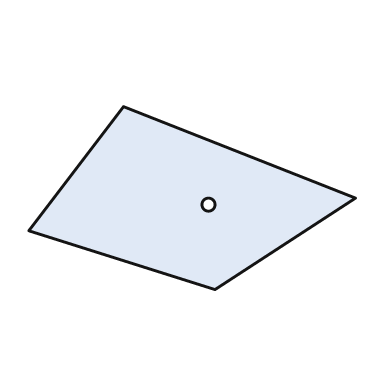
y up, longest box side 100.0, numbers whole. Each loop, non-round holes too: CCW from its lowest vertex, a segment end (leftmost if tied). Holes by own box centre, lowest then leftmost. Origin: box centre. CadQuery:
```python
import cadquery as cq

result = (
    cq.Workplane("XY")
    .moveTo(7.0, -28.0)
    .lineTo(50.0, 0.0)
    .lineTo(-21.0, 28.0)
    .lineTo(-50.0, -10.0)
    .close()
    .moveTo(5.0, -2.0)
    .circle(2.0)
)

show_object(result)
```